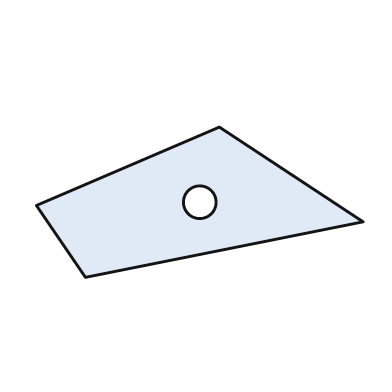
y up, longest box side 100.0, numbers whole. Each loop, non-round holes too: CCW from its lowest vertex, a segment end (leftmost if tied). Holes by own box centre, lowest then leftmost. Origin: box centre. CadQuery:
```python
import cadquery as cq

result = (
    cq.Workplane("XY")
    .moveTo(-35.0, -23.0)
    .lineTo(50.0, -6.0)
    .lineTo(6.0, 23.0)
    .lineTo(-50.0, -1.0)
    .close()
    .moveTo(0.0, 0.0)
    .circle(5.0)
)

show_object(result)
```